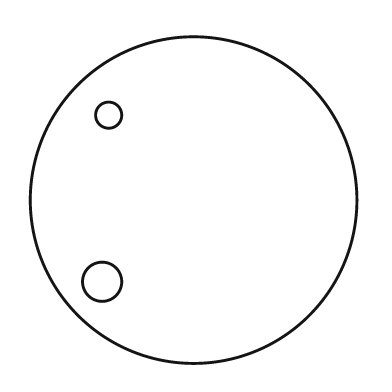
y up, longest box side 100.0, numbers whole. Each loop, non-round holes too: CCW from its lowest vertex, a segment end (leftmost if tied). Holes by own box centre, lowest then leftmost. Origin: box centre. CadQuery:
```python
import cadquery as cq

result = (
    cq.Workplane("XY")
    .moveTo(0.0, 0.0)
    .circle(50.0)
    .moveTo(-28.0, -25.0)
    .circle(6.0)
    .moveTo(-26.0, 26.0)
    .circle(4.0)
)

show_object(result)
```